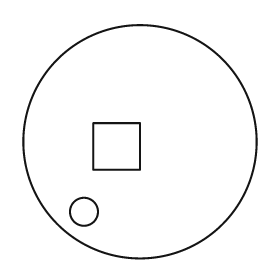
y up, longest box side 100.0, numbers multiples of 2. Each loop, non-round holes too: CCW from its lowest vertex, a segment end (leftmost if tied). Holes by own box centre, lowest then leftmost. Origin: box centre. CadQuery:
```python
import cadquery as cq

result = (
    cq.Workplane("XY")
    .moveTo(0.0, 0.0)
    .circle(50.0)
    .moveTo(-24.0, -30.0)
    .circle(6.0)
    .moveTo(-20.0, -12.0)
    .lineTo(0.0, -12.0)
    .lineTo(0.0, 8.0)
    .lineTo(-20.0, 8.0)
    .close()
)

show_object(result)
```